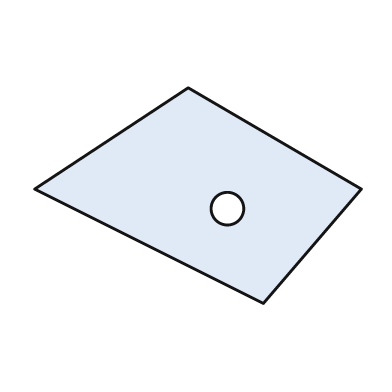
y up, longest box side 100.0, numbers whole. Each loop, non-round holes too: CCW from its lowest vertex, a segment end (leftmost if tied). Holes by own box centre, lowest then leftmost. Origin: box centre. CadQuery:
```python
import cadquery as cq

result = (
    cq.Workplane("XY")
    .moveTo(20.0, -33.0)
    .lineTo(50.0, 2.0)
    .lineTo(-3.0, 33.0)
    .lineTo(-50.0, 2.0)
    .close()
    .moveTo(9.0, -4.0)
    .circle(5.0)
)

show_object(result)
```